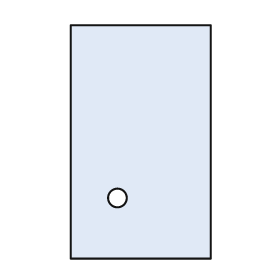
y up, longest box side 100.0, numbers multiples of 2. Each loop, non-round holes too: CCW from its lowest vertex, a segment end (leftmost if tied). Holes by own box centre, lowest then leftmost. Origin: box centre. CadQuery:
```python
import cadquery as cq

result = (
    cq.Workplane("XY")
    .moveTo(-30.0, -50.0)
    .lineTo(30.0, -50.0)
    .lineTo(30.0, 50.0)
    .lineTo(-30.0, 50.0)
    .close()
    .moveTo(-10.0, -24.0)
    .circle(4.0)
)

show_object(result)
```